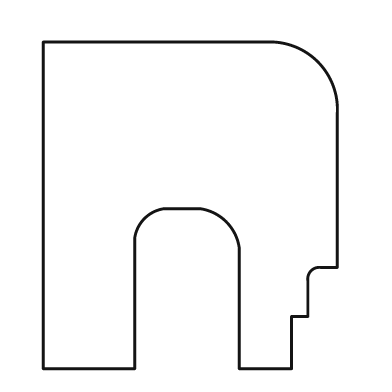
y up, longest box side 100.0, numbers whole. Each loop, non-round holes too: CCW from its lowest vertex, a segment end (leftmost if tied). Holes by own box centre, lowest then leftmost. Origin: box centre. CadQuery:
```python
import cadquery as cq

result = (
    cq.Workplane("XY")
    .moveTo(-45.0, -50.0)
    .lineTo(-17.0, -50.0)
    .lineTo(-17.0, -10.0)
    .threePointArc((-14.0, -4.0), (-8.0, -1.0))
    .lineTo(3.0, -1.0)
    .threePointArc((11.0, -5.0), (15.0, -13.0))
    .lineTo(15.0, -50.0)
    .lineTo(31.0, -50.0)
    .lineTo(31.0, -34.0)
    .lineTo(36.0, -34.0)
    .lineTo(36.0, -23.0)
    .threePointArc((37.0, -20.0), (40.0, -19.0))
    .lineTo(45.0, -19.0)
    .lineTo(45.0, 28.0)
    .threePointArc((39.0, 44.0), (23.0, 50.0))
    .lineTo(-45.0, 50.0)
    .close()
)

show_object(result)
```